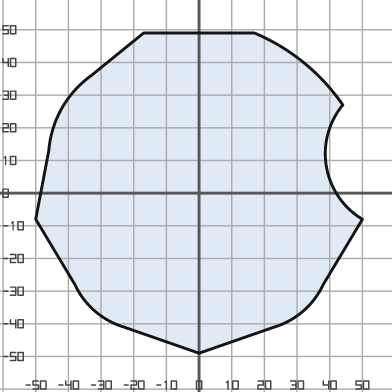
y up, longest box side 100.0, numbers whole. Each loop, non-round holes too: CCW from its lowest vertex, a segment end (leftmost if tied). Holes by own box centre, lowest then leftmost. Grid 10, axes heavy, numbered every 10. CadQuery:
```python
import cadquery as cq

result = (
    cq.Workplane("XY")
    .moveTo(0.0, -49.0)
    .lineTo(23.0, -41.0)
    .threePointArc((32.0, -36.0), (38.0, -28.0))
    .lineTo(50.0, -8.0)
    .threePointArc((39.0, 8.0), (44.0, 27.0))
    .threePointArc((32.0, 40.0), (17.0, 49.0))
    .lineTo(-17.0, 49.0)
    .lineTo(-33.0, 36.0)
    .threePointArc((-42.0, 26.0), (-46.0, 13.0))
    .lineTo(-50.0, -8.0)
    .lineTo(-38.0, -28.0)
    .threePointArc((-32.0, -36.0), (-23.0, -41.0))
    .close()
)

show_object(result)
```